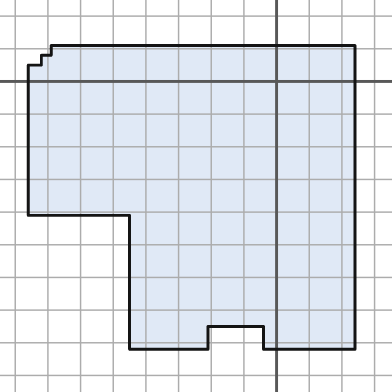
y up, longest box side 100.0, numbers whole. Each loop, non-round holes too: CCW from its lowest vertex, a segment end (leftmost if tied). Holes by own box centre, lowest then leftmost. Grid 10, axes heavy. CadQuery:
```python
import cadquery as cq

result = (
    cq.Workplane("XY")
    .moveTo(-45.0, -82.0)
    .lineTo(-21.0, -82.0)
    .lineTo(-21.0, -75.0)
    .lineTo(-4.0, -75.0)
    .lineTo(-4.0, -82.0)
    .lineTo(24.0, -82.0)
    .lineTo(24.0, 11.0)
    .lineTo(-69.0, 11.0)
    .lineTo(-69.0, 8.0)
    .lineTo(-72.0, 8.0)
    .lineTo(-72.0, 5.0)
    .lineTo(-76.0, 5.0)
    .lineTo(-76.0, -41.0)
    .lineTo(-45.0, -41.0)
    .close()
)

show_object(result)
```